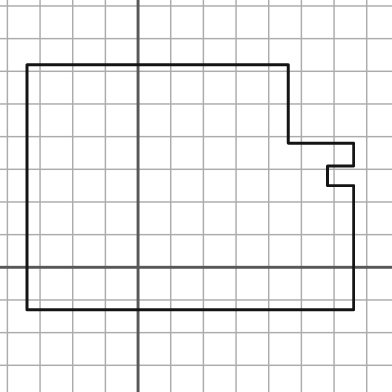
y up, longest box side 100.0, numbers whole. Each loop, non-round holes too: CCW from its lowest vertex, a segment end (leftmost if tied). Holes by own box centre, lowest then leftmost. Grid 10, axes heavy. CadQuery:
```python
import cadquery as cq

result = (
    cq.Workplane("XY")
    .moveTo(-34.0, -13.0)
    .lineTo(66.0, -13.0)
    .lineTo(66.0, 25.0)
    .lineTo(58.0, 25.0)
    .lineTo(58.0, 31.0)
    .lineTo(66.0, 31.0)
    .lineTo(66.0, 38.0)
    .lineTo(46.0, 38.0)
    .lineTo(46.0, 62.0)
    .lineTo(-34.0, 62.0)
    .close()
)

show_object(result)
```